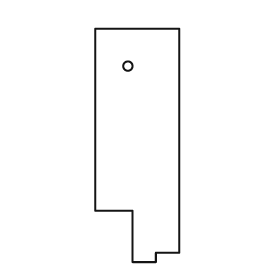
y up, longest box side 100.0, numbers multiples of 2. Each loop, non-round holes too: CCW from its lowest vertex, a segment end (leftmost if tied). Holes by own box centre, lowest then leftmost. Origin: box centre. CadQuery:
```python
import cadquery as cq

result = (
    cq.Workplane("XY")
    .moveTo(-2.0, -50.0)
    .lineTo(8.0, -50.0)
    .lineTo(8.0, -46.0)
    .lineTo(18.0, -46.0)
    .lineTo(18.0, 50.0)
    .lineTo(-18.0, 50.0)
    .lineTo(-18.0, -28.0)
    .lineTo(-2.0, -28.0)
    .close()
    .moveTo(-4.0, 34.0)
    .circle(2.0)
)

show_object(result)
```